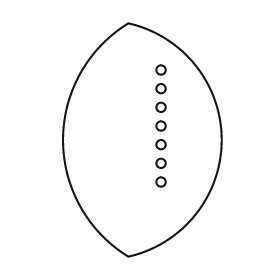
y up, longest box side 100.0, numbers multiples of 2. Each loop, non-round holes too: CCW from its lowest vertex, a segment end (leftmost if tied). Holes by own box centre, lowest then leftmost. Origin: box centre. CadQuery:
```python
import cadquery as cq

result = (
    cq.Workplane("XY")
    .moveTo(-6.0, -50.0)
    .threePointArc((34.0, 0.0), (-6.0, 50.0))
    .threePointArc((-34.0, 0.0), (-6.0, -50.0))
    .close()
    .moveTo(8.0, -18.0)
    .circle(2.0)
    .moveTo(8.0, -10.0)
    .circle(2.0)
    .moveTo(8.0, -2.0)
    .circle(2.0)
    .moveTo(8.0, 6.0)
    .circle(2.0)
    .moveTo(8.0, 14.0)
    .circle(2.0)
    .moveTo(8.0, 22.0)
    .circle(2.0)
    .moveTo(8.0, 30.0)
    .circle(2.0)
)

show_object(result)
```